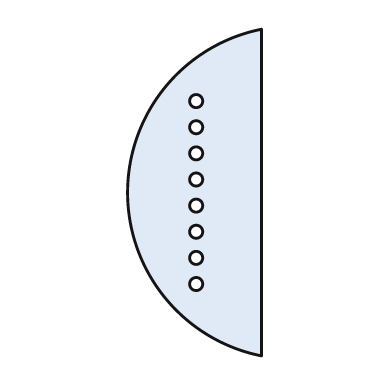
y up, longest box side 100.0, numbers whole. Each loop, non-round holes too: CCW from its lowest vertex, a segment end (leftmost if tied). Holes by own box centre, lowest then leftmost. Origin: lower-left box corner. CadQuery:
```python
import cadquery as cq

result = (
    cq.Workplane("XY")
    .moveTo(41.0, 0.0)
    .lineTo(41.0, 100.0)
    .threePointArc((0.0, 50.0), (41.0, 0.0))
    .close()
    .moveTo(21.0, 22.0)
    .circle(2.0)
    .moveTo(21.0, 30.0)
    .circle(2.0)
    .moveTo(21.0, 38.0)
    .circle(2.0)
    .moveTo(21.0, 46.0)
    .circle(2.0)
    .moveTo(21.0, 54.0)
    .circle(2.0)
    .moveTo(21.0, 62.0)
    .circle(2.0)
    .moveTo(21.0, 70.0)
    .circle(2.0)
    .moveTo(21.0, 78.0)
    .circle(2.0)
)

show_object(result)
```